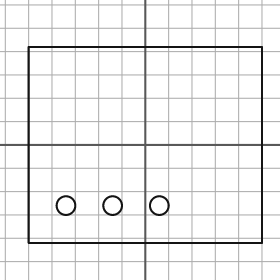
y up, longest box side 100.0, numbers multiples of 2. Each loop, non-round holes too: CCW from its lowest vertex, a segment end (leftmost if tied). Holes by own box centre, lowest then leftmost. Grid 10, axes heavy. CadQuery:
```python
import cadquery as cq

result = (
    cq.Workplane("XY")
    .moveTo(-50.0, -42.0)
    .lineTo(50.0, -42.0)
    .lineTo(50.0, 42.0)
    .lineTo(-50.0, 42.0)
    .close()
    .moveTo(-34.0, -26.0)
    .circle(4.0)
    .moveTo(-14.0, -26.0)
    .circle(4.0)
    .moveTo(6.0, -26.0)
    .circle(4.0)
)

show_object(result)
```